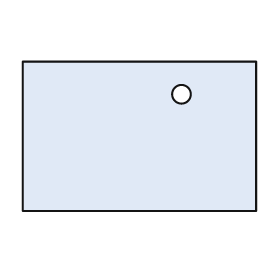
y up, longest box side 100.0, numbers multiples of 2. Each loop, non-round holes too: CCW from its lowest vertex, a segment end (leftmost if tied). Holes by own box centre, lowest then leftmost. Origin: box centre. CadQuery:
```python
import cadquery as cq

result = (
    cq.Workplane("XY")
    .moveTo(-50.0, -32.0)
    .lineTo(50.0, -32.0)
    .lineTo(50.0, 32.0)
    .lineTo(-50.0, 32.0)
    .close()
    .moveTo(18.0, 18.0)
    .circle(4.0)
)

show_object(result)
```